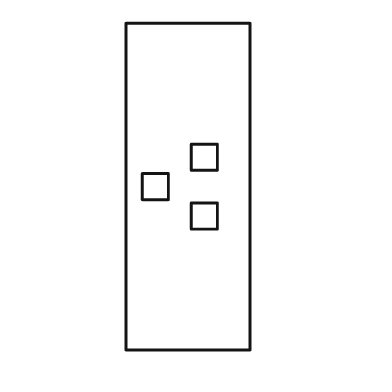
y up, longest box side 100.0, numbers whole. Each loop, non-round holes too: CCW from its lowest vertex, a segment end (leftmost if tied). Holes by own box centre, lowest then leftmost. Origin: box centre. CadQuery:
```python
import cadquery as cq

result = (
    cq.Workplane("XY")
    .moveTo(-19.0, -50.0)
    .lineTo(19.0, -50.0)
    .lineTo(19.0, 50.0)
    .lineTo(-19.0, 50.0)
    .close()
    .moveTo(1.0, -13.0)
    .lineTo(9.0, -13.0)
    .lineTo(9.0, -5.0)
    .lineTo(1.0, -5.0)
    .close()
    .moveTo(-14.0, -4.0)
    .lineTo(-6.0, -4.0)
    .lineTo(-6.0, 4.0)
    .lineTo(-14.0, 4.0)
    .close()
    .moveTo(1.0, 5.0)
    .lineTo(9.0, 5.0)
    .lineTo(9.0, 13.0)
    .lineTo(1.0, 13.0)
    .close()
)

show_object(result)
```